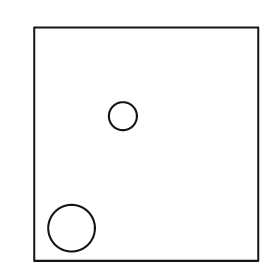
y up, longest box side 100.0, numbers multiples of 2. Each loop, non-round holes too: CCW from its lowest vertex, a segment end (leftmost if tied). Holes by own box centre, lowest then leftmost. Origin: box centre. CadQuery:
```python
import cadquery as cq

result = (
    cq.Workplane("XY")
    .moveTo(-48.0, -50.0)
    .lineTo(48.0, -50.0)
    .lineTo(48.0, 50.0)
    .lineTo(-48.0, 50.0)
    .close()
    .moveTo(-32.0, -36.0)
    .circle(10.0)
    .moveTo(-10.0, 12.0)
    .circle(6.0)
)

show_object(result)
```